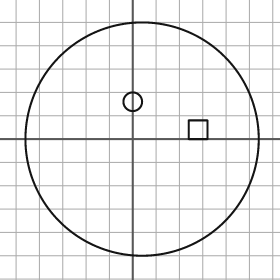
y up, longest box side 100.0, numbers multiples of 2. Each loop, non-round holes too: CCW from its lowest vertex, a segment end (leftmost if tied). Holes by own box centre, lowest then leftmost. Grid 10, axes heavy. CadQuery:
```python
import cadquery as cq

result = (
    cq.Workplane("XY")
    .moveTo(4.0, 0.0)
    .circle(50.0)
    .moveTo(24.0, 0.0)
    .lineTo(32.0, 0.0)
    .lineTo(32.0, 8.0)
    .lineTo(24.0, 8.0)
    .close()
    .moveTo(0.0, 16.0)
    .circle(4.0)
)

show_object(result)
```